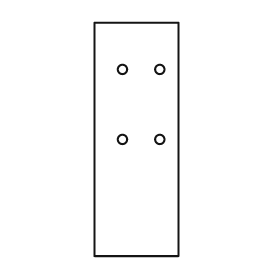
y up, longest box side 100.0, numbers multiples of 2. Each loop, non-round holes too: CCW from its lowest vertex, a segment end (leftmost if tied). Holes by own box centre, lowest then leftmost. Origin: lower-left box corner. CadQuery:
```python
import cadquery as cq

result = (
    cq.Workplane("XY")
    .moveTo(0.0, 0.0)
    .lineTo(36.0, 0.0)
    .lineTo(36.0, 100.0)
    .lineTo(0.0, 100.0)
    .close()
    .moveTo(12.0, 50.0)
    .circle(2.0)
    .moveTo(28.0, 50.0)
    .circle(2.0)
    .moveTo(12.0, 80.0)
    .circle(2.0)
    .moveTo(28.0, 80.0)
    .circle(2.0)
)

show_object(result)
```